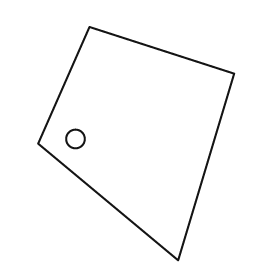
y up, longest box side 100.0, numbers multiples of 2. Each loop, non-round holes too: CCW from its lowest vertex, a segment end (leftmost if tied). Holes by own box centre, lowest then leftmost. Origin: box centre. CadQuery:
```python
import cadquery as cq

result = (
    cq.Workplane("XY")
    .moveTo(18.0, -50.0)
    .lineTo(42.0, 30.0)
    .lineTo(-20.0, 50.0)
    .lineTo(-42.0, 0.0)
    .close()
    .moveTo(-26.0, 2.0)
    .circle(4.0)
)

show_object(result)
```